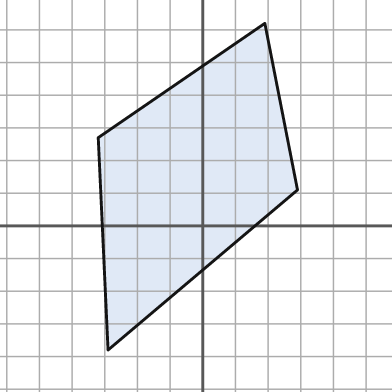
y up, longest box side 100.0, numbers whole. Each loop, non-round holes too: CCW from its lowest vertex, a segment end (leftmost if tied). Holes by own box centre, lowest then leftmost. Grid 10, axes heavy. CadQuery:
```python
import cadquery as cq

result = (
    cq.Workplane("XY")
    .moveTo(-29.0, -38.0)
    .lineTo(29.0, 11.0)
    .lineTo(19.0, 62.0)
    .lineTo(-32.0, 27.0)
    .close()
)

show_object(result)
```